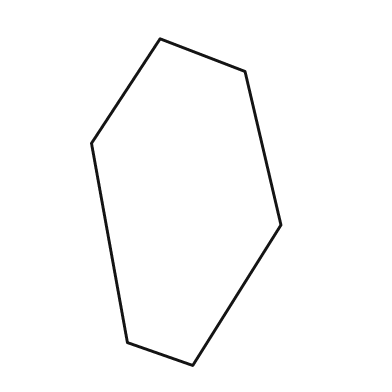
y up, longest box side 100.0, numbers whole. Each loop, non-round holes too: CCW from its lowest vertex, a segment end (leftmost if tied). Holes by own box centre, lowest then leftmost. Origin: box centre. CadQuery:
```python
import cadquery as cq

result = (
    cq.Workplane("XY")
    .moveTo(2.0, -50.0)
    .lineTo(29.0, -7.0)
    .lineTo(18.0, 40.0)
    .lineTo(-8.0, 50.0)
    .lineTo(-29.0, 18.0)
    .lineTo(-18.0, -43.0)
    .close()
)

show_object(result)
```